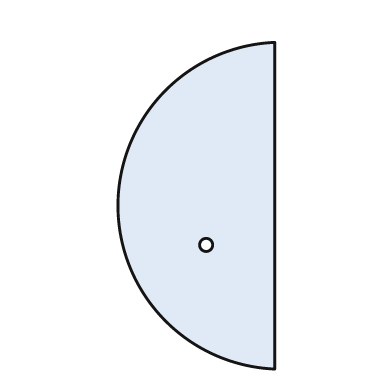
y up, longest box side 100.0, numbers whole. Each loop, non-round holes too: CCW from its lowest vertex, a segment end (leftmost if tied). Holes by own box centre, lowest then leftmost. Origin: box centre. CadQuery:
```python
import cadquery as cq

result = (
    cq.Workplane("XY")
    .moveTo(24.0, -50.0)
    .lineTo(24.0, 50.0)
    .threePointArc((-24.0, 0.0), (24.0, -50.0))
    .close()
    .moveTo(3.0, -12.0)
    .circle(2.0)
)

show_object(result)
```